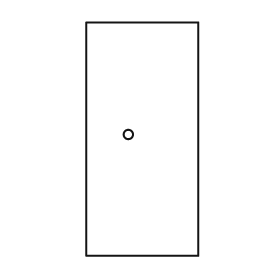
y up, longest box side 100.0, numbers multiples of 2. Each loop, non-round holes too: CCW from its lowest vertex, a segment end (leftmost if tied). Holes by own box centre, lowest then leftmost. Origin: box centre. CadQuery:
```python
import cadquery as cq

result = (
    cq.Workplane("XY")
    .moveTo(-24.0, -50.0)
    .lineTo(24.0, -50.0)
    .lineTo(24.0, 50.0)
    .lineTo(-24.0, 50.0)
    .close()
    .moveTo(-6.0, 2.0)
    .circle(2.0)
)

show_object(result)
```